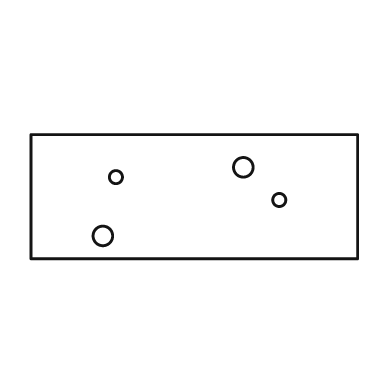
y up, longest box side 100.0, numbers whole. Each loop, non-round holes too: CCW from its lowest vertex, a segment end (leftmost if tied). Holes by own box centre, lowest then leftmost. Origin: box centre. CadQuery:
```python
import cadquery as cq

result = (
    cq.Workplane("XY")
    .moveTo(-50.0, -19.0)
    .lineTo(50.0, -19.0)
    .lineTo(50.0, 19.0)
    .lineTo(-50.0, 19.0)
    .close()
    .moveTo(-28.0, -12.0)
    .circle(3.0)
    .moveTo(26.0, -1.0)
    .circle(2.0)
    .moveTo(-24.0, 6.0)
    .circle(2.0)
    .moveTo(15.0, 9.0)
    .circle(3.0)
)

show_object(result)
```